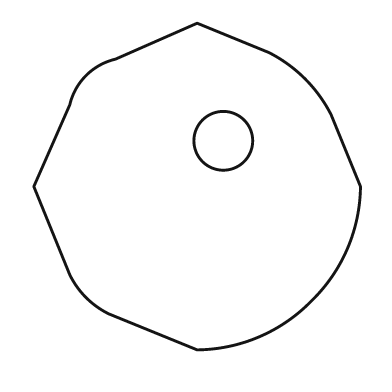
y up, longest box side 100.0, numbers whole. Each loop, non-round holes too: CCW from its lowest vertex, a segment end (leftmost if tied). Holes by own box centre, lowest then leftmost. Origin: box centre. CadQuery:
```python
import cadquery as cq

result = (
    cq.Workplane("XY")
    .moveTo(0.0, -50.0)
    .threePointArc((19.0, -46.0), (35.0, -35.0))
    .threePointArc((46.0, -19.0), (50.0, 0.0))
    .lineTo(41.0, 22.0)
    .threePointArc((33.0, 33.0), (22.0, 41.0))
    .lineTo(0.0, 50.0)
    .lineTo(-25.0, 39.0)
    .threePointArc((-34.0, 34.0), (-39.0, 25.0))
    .lineTo(-50.0, 0.0)
    .lineTo(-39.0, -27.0)
    .threePointArc((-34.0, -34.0), (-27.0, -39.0))
    .close()
    .moveTo(8.0, 14.0)
    .circle(9.0)
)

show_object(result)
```